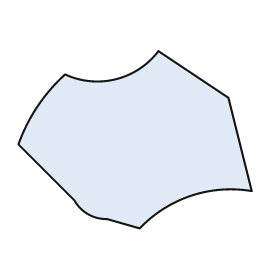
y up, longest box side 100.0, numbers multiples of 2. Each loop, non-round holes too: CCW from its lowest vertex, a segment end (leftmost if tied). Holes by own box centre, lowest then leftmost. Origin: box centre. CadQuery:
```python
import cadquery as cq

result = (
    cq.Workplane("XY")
    .moveTo(2.0, -38.0)
    .threePointArc((24.0, -24.0), (50.0, -22.0))
    .lineTo(40.0, 18.0)
    .lineTo(10.0, 38.0)
    .threePointArc((-8.0, 26.0), (-30.0, 28.0))
    .threePointArc((-42.0, 14.0), (-50.0, -2.0))
    .lineTo(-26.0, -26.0)
    .threePointArc((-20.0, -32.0), (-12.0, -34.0))
    .close()
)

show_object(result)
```